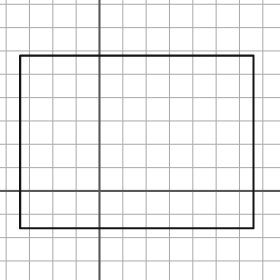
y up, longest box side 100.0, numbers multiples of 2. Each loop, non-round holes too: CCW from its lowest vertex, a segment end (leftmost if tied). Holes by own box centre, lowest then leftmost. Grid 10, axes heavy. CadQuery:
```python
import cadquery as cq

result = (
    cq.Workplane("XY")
    .moveTo(-34.0, -16.0)
    .lineTo(66.0, -16.0)
    .lineTo(66.0, 58.0)
    .lineTo(-34.0, 58.0)
    .close()
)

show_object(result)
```